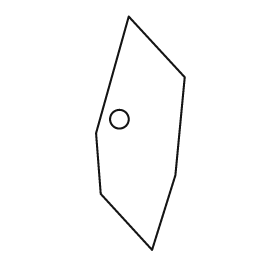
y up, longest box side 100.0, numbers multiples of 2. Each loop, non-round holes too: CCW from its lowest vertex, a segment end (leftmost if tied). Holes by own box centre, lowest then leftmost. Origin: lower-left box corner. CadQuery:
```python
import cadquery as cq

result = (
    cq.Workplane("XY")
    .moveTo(24.0, 0.0)
    .lineTo(34.0, 32.0)
    .lineTo(38.0, 74.0)
    .lineTo(14.0, 100.0)
    .lineTo(0.0, 50.0)
    .lineTo(2.0, 24.0)
    .close()
    .moveTo(10.0, 56.0)
    .circle(4.0)
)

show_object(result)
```